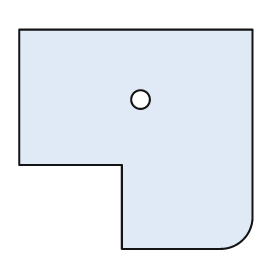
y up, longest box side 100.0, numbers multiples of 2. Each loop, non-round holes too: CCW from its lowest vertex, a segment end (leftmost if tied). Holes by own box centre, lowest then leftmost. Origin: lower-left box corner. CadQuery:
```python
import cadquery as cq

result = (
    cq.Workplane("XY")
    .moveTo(44.0, 0.0)
    .lineTo(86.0, 0.0)
    .threePointArc((96.0, 4.0), (100.0, 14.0))
    .lineTo(100.0, 94.0)
    .lineTo(0.0, 94.0)
    .lineTo(0.0, 36.0)
    .lineTo(44.0, 36.0)
    .close()
    .moveTo(52.0, 64.0)
    .circle(4.0)
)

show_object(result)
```